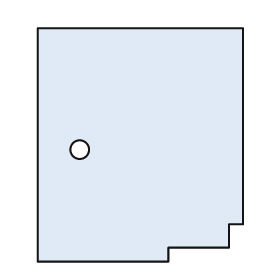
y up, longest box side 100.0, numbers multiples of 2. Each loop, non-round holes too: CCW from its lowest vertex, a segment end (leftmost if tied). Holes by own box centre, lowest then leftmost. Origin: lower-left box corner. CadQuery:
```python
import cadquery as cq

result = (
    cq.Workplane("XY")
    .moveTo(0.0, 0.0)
    .lineTo(56.0, 0.0)
    .lineTo(56.0, 6.0)
    .lineTo(82.0, 6.0)
    .lineTo(82.0, 16.0)
    .lineTo(88.0, 16.0)
    .lineTo(88.0, 100.0)
    .lineTo(0.0, 100.0)
    .close()
    .moveTo(18.0, 48.0)
    .circle(4.0)
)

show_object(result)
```